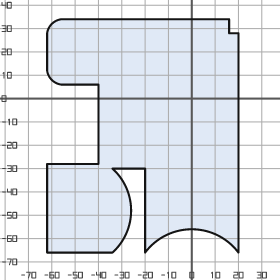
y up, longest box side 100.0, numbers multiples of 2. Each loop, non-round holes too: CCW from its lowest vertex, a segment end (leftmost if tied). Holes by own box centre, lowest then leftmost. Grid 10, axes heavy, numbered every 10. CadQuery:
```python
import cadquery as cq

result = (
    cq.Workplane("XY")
    .moveTo(-62.0, -66.0)
    .lineTo(-34.0, -66.0)
    .threePointArc((-26.0, -48.0), (-34.0, -30.0))
    .lineTo(-20.0, -30.0)
    .lineTo(-20.0, -66.0)
    .threePointArc((0.0, -56.0), (20.0, -66.0))
    .lineTo(20.0, 28.0)
    .lineTo(16.0, 28.0)
    .lineTo(16.0, 34.0)
    .lineTo(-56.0, 34.0)
    .threePointArc((-60.0, 32.0), (-62.0, 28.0))
    .lineTo(-62.0, 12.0)
    .threePointArc((-60.0, 8.0), (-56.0, 6.0))
    .lineTo(-40.0, 6.0)
    .lineTo(-40.0, -28.0)
    .lineTo(-62.0, -28.0)
    .close()
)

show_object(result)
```